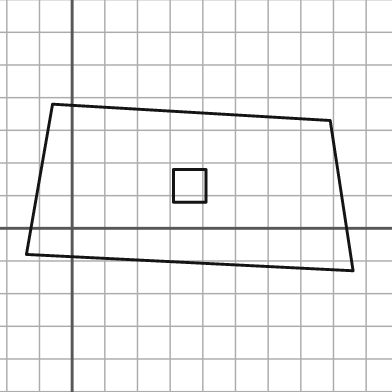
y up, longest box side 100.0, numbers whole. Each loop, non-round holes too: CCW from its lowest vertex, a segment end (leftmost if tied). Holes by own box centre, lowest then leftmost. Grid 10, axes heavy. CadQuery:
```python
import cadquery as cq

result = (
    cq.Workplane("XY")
    .moveTo(86.0, -13.0)
    .lineTo(79.0, 33.0)
    .lineTo(-6.0, 38.0)
    .lineTo(-14.0, -8.0)
    .close()
    .moveTo(31.0, 8.0)
    .lineTo(41.0, 8.0)
    .lineTo(41.0, 18.0)
    .lineTo(31.0, 18.0)
    .close()
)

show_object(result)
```